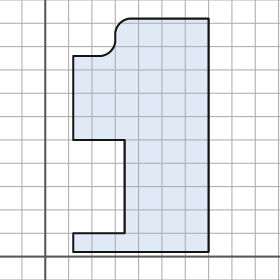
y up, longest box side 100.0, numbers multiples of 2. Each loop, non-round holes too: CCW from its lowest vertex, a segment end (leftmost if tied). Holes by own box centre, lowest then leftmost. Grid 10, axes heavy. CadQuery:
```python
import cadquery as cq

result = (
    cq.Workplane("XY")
    .moveTo(12.0, 2.0)
    .lineTo(70.0, 2.0)
    .lineTo(70.0, 102.0)
    .lineTo(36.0, 102.0)
    .threePointArc((32.0, 100.0), (30.0, 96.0))
    .lineTo(30.0, 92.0)
    .threePointArc((28.0, 88.0), (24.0, 86.0))
    .lineTo(12.0, 86.0)
    .lineTo(12.0, 50.0)
    .lineTo(34.0, 50.0)
    .lineTo(34.0, 10.0)
    .lineTo(12.0, 10.0)
    .close()
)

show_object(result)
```